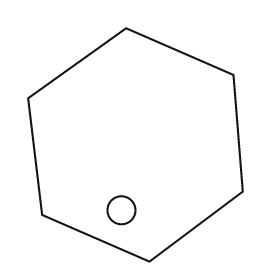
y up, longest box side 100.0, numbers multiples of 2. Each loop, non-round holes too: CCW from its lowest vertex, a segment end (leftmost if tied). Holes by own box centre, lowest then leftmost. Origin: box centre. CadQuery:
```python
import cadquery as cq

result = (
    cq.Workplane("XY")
    .moveTo(6.0, -50.0)
    .lineTo(46.0, -20.0)
    .lineTo(42.0, 30.0)
    .lineTo(-4.0, 50.0)
    .lineTo(-46.0, 20.0)
    .lineTo(-40.0, -30.0)
    .close()
    .moveTo(-6.0, -28.0)
    .circle(6.0)
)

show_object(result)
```